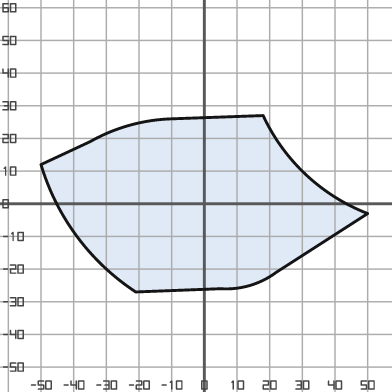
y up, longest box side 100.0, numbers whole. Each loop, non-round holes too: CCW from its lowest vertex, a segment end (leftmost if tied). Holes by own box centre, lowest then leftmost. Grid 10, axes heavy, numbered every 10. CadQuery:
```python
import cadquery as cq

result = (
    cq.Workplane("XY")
    .moveTo(-21.0, -27.0)
    .lineTo(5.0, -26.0)
    .threePointArc((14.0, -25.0), (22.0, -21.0))
    .lineTo(50.0, -3.0)
    .threePointArc((31.0, 9.0), (18.0, 27.0))
    .lineTo(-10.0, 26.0)
    .threePointArc((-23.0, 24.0), (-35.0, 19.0))
    .lineTo(-50.0, 12.0)
    .threePointArc((-39.0, -10.0), (-21.0, -27.0))
    .close()
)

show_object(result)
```